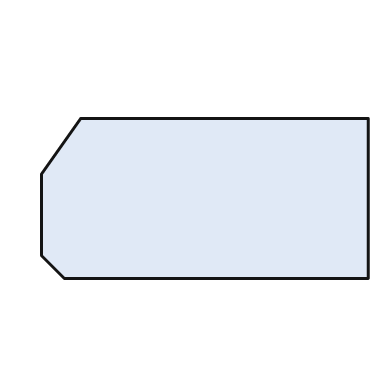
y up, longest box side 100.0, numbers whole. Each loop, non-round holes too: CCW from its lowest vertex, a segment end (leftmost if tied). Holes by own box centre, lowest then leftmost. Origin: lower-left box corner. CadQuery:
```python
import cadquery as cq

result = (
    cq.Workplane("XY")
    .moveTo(7.0, 0.0)
    .lineTo(100.0, 0.0)
    .lineTo(100.0, 49.0)
    .lineTo(12.0, 49.0)
    .lineTo(0.0, 32.0)
    .lineTo(0.0, 7.0)
    .close()
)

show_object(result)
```